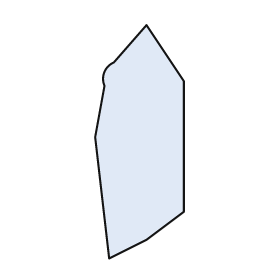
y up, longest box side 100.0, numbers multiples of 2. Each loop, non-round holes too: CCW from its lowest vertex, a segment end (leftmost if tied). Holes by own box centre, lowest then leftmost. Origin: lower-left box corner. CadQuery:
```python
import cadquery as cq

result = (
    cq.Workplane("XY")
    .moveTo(6.0, 0.0)
    .lineTo(22.0, 8.0)
    .lineTo(38.0, 20.0)
    .lineTo(38.0, 76.0)
    .lineTo(22.0, 100.0)
    .lineTo(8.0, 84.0)
    .threePointArc((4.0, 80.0), (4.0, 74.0))
    .lineTo(0.0, 52.0)
    .close()
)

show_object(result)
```